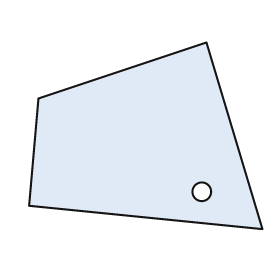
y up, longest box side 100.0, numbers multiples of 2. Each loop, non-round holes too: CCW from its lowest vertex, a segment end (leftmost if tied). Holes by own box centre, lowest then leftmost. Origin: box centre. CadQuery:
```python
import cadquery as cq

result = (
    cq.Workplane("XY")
    .moveTo(50.0, -40.0)
    .lineTo(26.0, 40.0)
    .lineTo(-46.0, 16.0)
    .lineTo(-50.0, -30.0)
    .close()
    .moveTo(24.0, -24.0)
    .circle(4.0)
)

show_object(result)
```